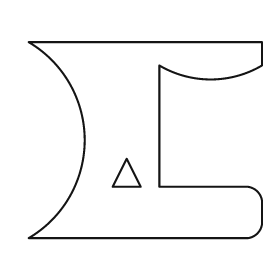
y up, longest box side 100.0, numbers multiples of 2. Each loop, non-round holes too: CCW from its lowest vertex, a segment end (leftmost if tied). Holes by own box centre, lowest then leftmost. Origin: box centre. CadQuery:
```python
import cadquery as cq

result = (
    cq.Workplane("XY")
    .moveTo(-50.0, -42.0)
    .lineTo(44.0, -42.0)
    .threePointArc((48.0, -40.0), (50.0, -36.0))
    .lineTo(50.0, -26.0)
    .threePointArc((48.0, -22.0), (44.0, -20.0))
    .lineTo(6.0, -20.0)
    .lineTo(6.0, 32.0)
    .threePointArc((28.0, 26.0), (50.0, 32.0))
    .lineTo(50.0, 42.0)
    .lineTo(-50.0, 42.0)
    .threePointArc((-26.0, 0.0), (-50.0, -42.0))
    .close()
    .moveTo(-14.0, -20.0)
    .lineTo(-2.0, -20.0)
    .lineTo(-8.0, -8.0)
    .close()
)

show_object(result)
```